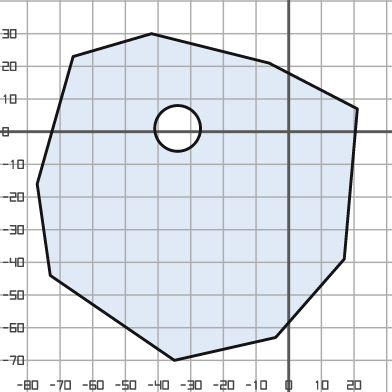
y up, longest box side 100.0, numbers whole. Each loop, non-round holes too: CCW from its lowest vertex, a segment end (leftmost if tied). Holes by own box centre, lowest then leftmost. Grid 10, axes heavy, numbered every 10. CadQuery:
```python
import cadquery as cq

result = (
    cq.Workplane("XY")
    .moveTo(-35.0, -70.0)
    .lineTo(-4.0, -63.0)
    .lineTo(17.0, -39.0)
    .lineTo(21.0, 7.0)
    .lineTo(-6.0, 21.0)
    .lineTo(-42.0, 30.0)
    .lineTo(-66.0, 23.0)
    .lineTo(-77.0, -16.0)
    .lineTo(-73.0, -44.0)
    .close()
    .moveTo(-34.0, 1.0)
    .circle(7.0)
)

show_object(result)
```